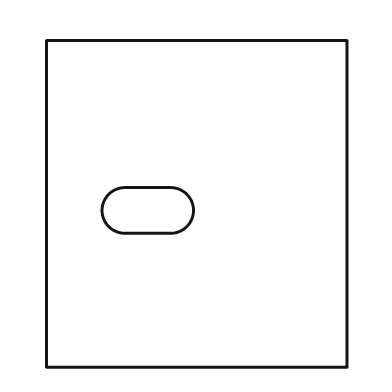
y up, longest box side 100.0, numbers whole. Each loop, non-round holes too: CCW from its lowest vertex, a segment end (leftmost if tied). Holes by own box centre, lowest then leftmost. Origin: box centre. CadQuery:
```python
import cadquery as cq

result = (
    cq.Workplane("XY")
    .moveTo(-46.0, -50.0)
    .lineTo(46.0, -50.0)
    .lineTo(46.0, 50.0)
    .lineTo(-46.0, 50.0)
    .close()
    .moveTo(-22.0, -9.0)
    .lineTo(-8.0, -9.0)
    .threePointArc((-1.0, -2.0), (-8.0, 5.0))
    .lineTo(-22.0, 5.0)
    .threePointArc((-29.0, -2.0), (-22.0, -9.0))
    .close()
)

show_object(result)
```